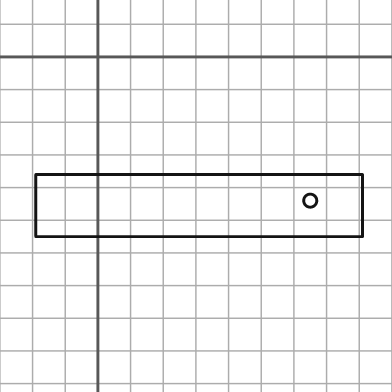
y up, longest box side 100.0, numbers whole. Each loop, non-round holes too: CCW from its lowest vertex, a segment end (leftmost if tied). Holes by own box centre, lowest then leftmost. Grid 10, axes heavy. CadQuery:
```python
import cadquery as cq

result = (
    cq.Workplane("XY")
    .moveTo(-19.0, -55.0)
    .lineTo(81.0, -55.0)
    .lineTo(81.0, -36.0)
    .lineTo(-19.0, -36.0)
    .close()
    .moveTo(65.0, -44.0)
    .circle(2.0)
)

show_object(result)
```